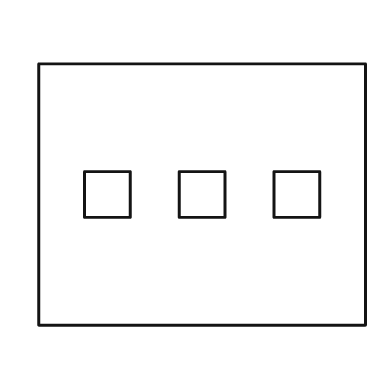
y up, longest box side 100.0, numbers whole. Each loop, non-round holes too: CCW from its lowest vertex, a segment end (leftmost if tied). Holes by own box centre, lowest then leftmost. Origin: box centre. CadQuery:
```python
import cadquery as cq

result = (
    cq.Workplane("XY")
    .moveTo(-50.0, -40.0)
    .lineTo(50.0, -40.0)
    .lineTo(50.0, 40.0)
    .lineTo(-50.0, 40.0)
    .close()
    .moveTo(-36.0, -7.0)
    .lineTo(-22.0, -7.0)
    .lineTo(-22.0, 7.0)
    .lineTo(-36.0, 7.0)
    .close()
    .moveTo(-7.0, -7.0)
    .lineTo(7.0, -7.0)
    .lineTo(7.0, 7.0)
    .lineTo(-7.0, 7.0)
    .close()
    .moveTo(22.0, -7.0)
    .lineTo(36.0, -7.0)
    .lineTo(36.0, 7.0)
    .lineTo(22.0, 7.0)
    .close()
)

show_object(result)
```